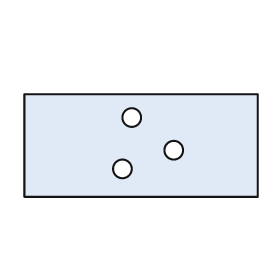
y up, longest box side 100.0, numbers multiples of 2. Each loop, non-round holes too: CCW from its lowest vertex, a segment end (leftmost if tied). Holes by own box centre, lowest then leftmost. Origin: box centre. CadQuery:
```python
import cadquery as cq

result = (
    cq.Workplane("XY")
    .moveTo(-50.0, -22.0)
    .lineTo(50.0, -22.0)
    .lineTo(50.0, 22.0)
    .lineTo(-50.0, 22.0)
    .close()
    .moveTo(-8.0, -10.0)
    .circle(4.0)
    .moveTo(14.0, -2.0)
    .circle(4.0)
    .moveTo(-4.0, 12.0)
    .circle(4.0)
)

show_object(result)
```